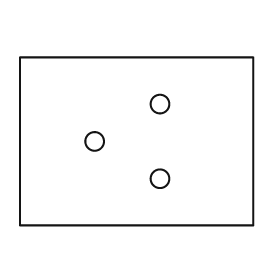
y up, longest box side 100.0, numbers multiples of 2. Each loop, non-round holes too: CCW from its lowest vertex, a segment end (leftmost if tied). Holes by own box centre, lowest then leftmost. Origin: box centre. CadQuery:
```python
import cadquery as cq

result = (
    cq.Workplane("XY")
    .moveTo(-50.0, -36.0)
    .lineTo(50.0, -36.0)
    .lineTo(50.0, 36.0)
    .lineTo(-50.0, 36.0)
    .close()
    .moveTo(10.0, -16.0)
    .circle(4.0)
    .moveTo(-18.0, 0.0)
    .circle(4.0)
    .moveTo(10.0, 16.0)
    .circle(4.0)
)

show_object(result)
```